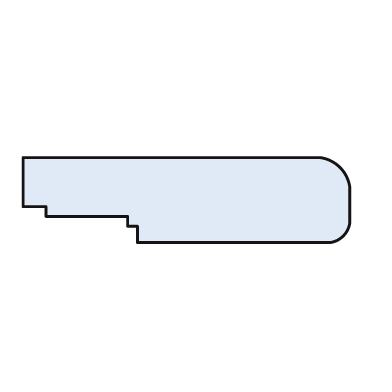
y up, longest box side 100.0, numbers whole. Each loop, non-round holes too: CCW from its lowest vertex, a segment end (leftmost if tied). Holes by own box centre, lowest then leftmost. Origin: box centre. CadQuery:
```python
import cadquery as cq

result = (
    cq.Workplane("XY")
    .moveTo(-15.0, -13.0)
    .lineTo(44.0, -13.0)
    .threePointArc((48.0, -11.0), (50.0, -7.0))
    .lineTo(50.0, 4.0)
    .threePointArc((47.0, 10.0), (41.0, 13.0))
    .lineTo(-50.0, 13.0)
    .lineTo(-50.0, -2.0)
    .lineTo(-43.0, -2.0)
    .lineTo(-43.0, -5.0)
    .lineTo(-18.0, -5.0)
    .lineTo(-18.0, -8.0)
    .lineTo(-15.0, -8.0)
    .close()
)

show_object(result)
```